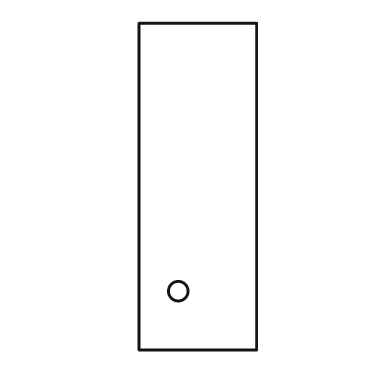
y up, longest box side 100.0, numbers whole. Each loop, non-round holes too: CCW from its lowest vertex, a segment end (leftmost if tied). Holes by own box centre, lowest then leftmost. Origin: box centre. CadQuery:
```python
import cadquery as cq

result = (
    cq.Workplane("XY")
    .moveTo(-18.0, -50.0)
    .lineTo(18.0, -50.0)
    .lineTo(18.0, 50.0)
    .lineTo(-18.0, 50.0)
    .close()
    .moveTo(-6.0, -32.0)
    .circle(3.0)
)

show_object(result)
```